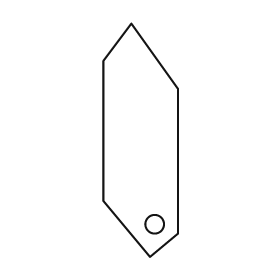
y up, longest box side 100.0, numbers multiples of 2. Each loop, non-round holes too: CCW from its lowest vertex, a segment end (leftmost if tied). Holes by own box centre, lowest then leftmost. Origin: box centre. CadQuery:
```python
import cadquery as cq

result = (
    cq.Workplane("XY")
    .moveTo(4.0, -50.0)
    .lineTo(16.0, -40.0)
    .lineTo(16.0, 22.0)
    .lineTo(-4.0, 50.0)
    .lineTo(-16.0, 34.0)
    .lineTo(-16.0, -26.0)
    .close()
    .moveTo(6.0, -36.0)
    .circle(4.0)
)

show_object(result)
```